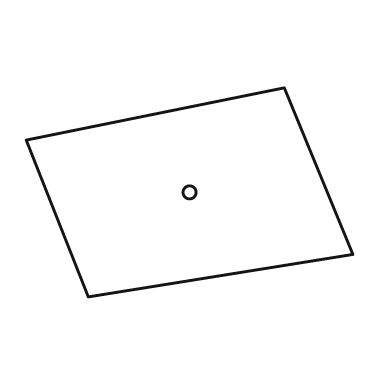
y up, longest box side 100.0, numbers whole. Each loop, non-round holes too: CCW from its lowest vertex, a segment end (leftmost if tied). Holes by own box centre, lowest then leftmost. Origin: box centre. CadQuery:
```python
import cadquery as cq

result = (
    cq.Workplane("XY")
    .moveTo(-31.0, -32.0)
    .lineTo(50.0, -19.0)
    .lineTo(29.0, 32.0)
    .lineTo(-50.0, 16.0)
    .close()
    .moveTo(0.0, 0.0)
    .circle(2.0)
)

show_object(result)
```